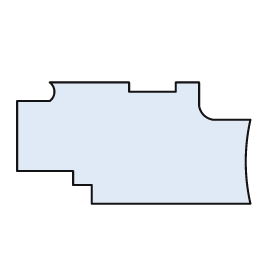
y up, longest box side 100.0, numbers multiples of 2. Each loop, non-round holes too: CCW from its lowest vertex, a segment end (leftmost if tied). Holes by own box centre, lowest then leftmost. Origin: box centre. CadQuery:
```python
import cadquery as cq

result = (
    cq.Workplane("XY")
    .moveTo(-18.0, -26.0)
    .lineTo(50.0, -26.0)
    .threePointArc((48.0, -8.0), (50.0, 10.0))
    .lineTo(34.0, 10.0)
    .threePointArc((30.0, 12.0), (28.0, 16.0))
    .lineTo(28.0, 26.0)
    .lineTo(18.0, 26.0)
    .lineTo(18.0, 22.0)
    .lineTo(-2.0, 22.0)
    .lineTo(-2.0, 26.0)
    .lineTo(-36.0, 26.0)
    .threePointArc((-34.0, 22.0), (-36.0, 18.0))
    .lineTo(-50.0, 18.0)
    .lineTo(-50.0, -12.0)
    .lineTo(-26.0, -12.0)
    .lineTo(-26.0, -18.0)
    .lineTo(-18.0, -18.0)
    .close()
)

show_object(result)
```